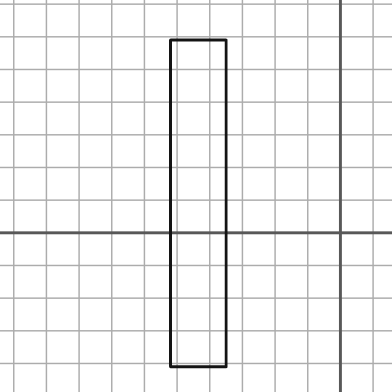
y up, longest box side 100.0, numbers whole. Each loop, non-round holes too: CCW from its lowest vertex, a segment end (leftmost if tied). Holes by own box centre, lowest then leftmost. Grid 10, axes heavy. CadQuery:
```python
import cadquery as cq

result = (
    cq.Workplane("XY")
    .moveTo(-52.0, -41.0)
    .lineTo(-35.0, -41.0)
    .lineTo(-35.0, 59.0)
    .lineTo(-52.0, 59.0)
    .close()
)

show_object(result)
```